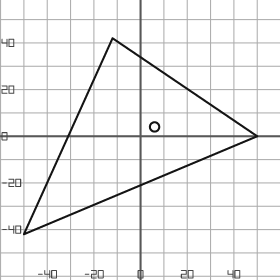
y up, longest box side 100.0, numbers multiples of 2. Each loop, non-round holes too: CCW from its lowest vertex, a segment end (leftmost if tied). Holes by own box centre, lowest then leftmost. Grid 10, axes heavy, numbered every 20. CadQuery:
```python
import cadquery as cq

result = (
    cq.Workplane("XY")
    .moveTo(-50.0, -42.0)
    .lineTo(50.0, 0.0)
    .lineTo(-12.0, 42.0)
    .close()
    .moveTo(6.0, 4.0)
    .circle(2.0)
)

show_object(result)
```